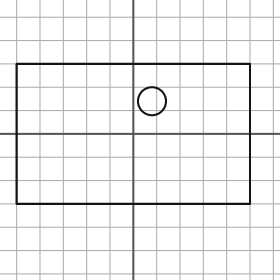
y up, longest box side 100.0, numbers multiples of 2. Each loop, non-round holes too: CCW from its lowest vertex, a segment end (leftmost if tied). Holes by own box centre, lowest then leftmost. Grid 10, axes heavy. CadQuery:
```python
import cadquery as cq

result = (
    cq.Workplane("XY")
    .moveTo(-50.0, -30.0)
    .lineTo(50.0, -30.0)
    .lineTo(50.0, 30.0)
    .lineTo(-50.0, 30.0)
    .close()
    .moveTo(8.0, 14.0)
    .circle(6.0)
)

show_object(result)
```